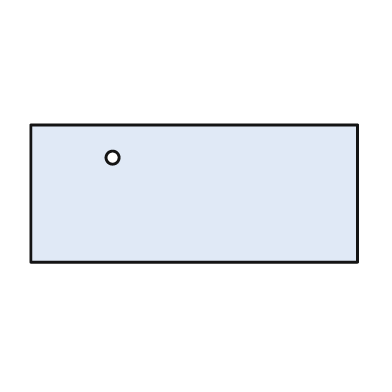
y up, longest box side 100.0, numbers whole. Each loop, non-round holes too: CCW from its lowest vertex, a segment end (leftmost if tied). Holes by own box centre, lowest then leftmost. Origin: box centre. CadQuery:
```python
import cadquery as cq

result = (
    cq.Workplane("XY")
    .moveTo(-50.0, -21.0)
    .lineTo(50.0, -21.0)
    .lineTo(50.0, 21.0)
    .lineTo(-50.0, 21.0)
    .close()
    .moveTo(-25.0, 11.0)
    .circle(2.0)
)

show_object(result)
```